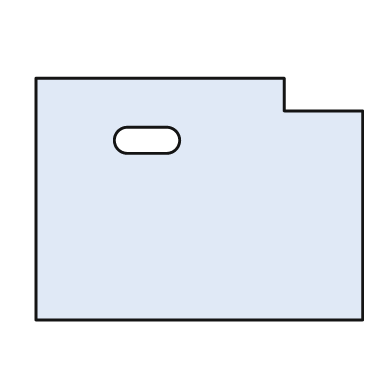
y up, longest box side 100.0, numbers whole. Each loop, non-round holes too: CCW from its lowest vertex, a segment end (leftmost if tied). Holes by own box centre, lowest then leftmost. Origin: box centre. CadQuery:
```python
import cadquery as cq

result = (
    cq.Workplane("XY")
    .moveTo(-50.0, -37.0)
    .lineTo(50.0, -37.0)
    .lineTo(50.0, 27.0)
    .lineTo(26.0, 27.0)
    .lineTo(26.0, 37.0)
    .lineTo(-50.0, 37.0)
    .close()
    .moveTo(-22.0, 14.0)
    .lineTo(-10.0, 14.0)
    .threePointArc((-6.0, 18.0), (-10.0, 22.0))
    .lineTo(-22.0, 22.0)
    .threePointArc((-26.0, 18.0), (-22.0, 14.0))
    .close()
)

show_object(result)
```